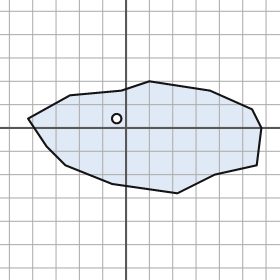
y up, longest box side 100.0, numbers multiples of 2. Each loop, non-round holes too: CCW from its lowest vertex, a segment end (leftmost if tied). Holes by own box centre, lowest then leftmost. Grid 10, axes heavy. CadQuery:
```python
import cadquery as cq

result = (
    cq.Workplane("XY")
    .moveTo(22.0, -28.0)
    .lineTo(38.0, -20.0)
    .lineTo(56.0, -16.0)
    .lineTo(58.0, 0.0)
    .lineTo(54.0, 8.0)
    .lineTo(36.0, 16.0)
    .lineTo(10.0, 20.0)
    .lineTo(-2.0, 16.0)
    .lineTo(-24.0, 14.0)
    .lineTo(-42.0, 4.0)
    .lineTo(-34.0, -8.0)
    .lineTo(-26.0, -16.0)
    .lineTo(-6.0, -24.0)
    .close()
    .moveTo(-4.0, 4.0)
    .circle(2.0)
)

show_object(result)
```